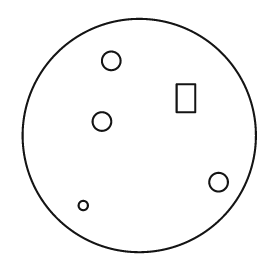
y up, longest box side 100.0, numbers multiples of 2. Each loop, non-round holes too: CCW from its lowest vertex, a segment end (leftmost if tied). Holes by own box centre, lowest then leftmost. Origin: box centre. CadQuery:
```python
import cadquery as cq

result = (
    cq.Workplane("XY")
    .moveTo(0.0, 0.0)
    .circle(50.0)
    .moveTo(-24.0, -30.0)
    .circle(2.0)
    .moveTo(34.0, -20.0)
    .circle(4.0)
    .moveTo(-16.0, 6.0)
    .circle(4.0)
    .moveTo(16.0, 10.0)
    .lineTo(24.0, 10.0)
    .lineTo(24.0, 22.0)
    .lineTo(16.0, 22.0)
    .close()
    .moveTo(-12.0, 32.0)
    .circle(4.0)
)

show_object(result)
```